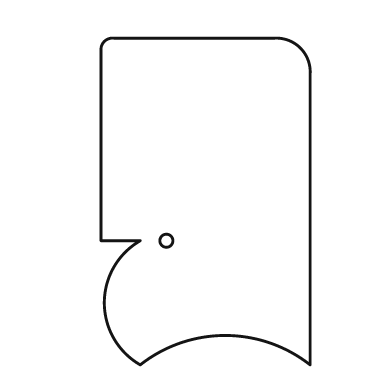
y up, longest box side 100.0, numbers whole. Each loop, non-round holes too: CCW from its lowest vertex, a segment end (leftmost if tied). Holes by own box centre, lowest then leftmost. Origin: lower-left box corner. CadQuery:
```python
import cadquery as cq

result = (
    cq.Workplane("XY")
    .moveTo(12.0, 0.0)
    .threePointArc((38.0, 9.0), (64.0, 0.0))
    .lineTo(64.0, 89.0)
    .threePointArc((61.0, 97.0), (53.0, 100.0))
    .lineTo(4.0, 100.0)
    .threePointArc((1.0, 99.0), (0.0, 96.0))
    .lineTo(0.0, 38.0)
    .lineTo(12.0, 38.0)
    .threePointArc((1.0, 19.0), (12.0, 0.0))
    .close()
    .moveTo(20.0, 38.0)
    .circle(2.0)
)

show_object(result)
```